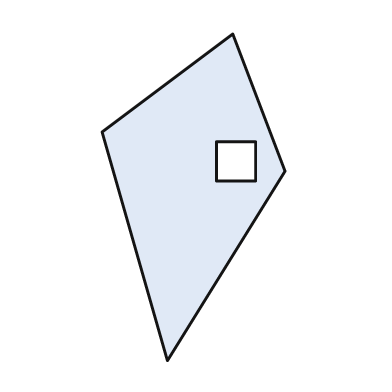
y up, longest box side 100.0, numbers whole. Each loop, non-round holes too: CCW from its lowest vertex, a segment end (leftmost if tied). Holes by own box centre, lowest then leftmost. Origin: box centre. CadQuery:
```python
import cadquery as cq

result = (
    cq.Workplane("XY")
    .moveTo(-8.0, -50.0)
    .lineTo(28.0, 8.0)
    .lineTo(12.0, 50.0)
    .lineTo(-28.0, 20.0)
    .close()
    .moveTo(7.0, 5.0)
    .lineTo(19.0, 5.0)
    .lineTo(19.0, 17.0)
    .lineTo(7.0, 17.0)
    .close()
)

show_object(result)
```